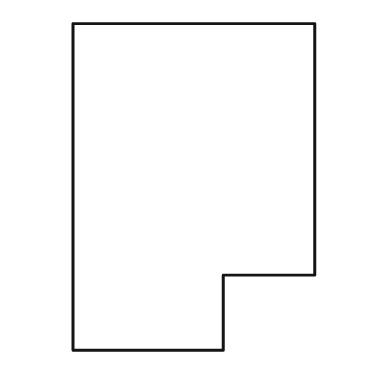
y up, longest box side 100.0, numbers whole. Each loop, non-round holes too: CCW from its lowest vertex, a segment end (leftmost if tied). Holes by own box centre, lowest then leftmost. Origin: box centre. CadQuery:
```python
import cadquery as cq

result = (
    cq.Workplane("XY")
    .moveTo(-37.0, -50.0)
    .lineTo(9.0, -50.0)
    .lineTo(9.0, -27.0)
    .lineTo(37.0, -27.0)
    .lineTo(37.0, 50.0)
    .lineTo(-37.0, 50.0)
    .close()
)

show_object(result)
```